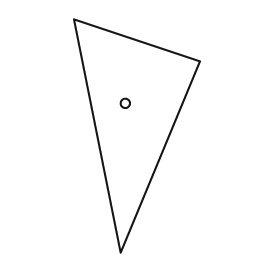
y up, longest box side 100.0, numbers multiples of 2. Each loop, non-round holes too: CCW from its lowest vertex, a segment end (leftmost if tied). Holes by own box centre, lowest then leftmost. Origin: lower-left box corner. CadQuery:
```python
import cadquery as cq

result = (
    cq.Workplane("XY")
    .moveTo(20.0, 0.0)
    .lineTo(54.0, 82.0)
    .lineTo(0.0, 100.0)
    .close()
    .moveTo(22.0, 64.0)
    .circle(2.0)
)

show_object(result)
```